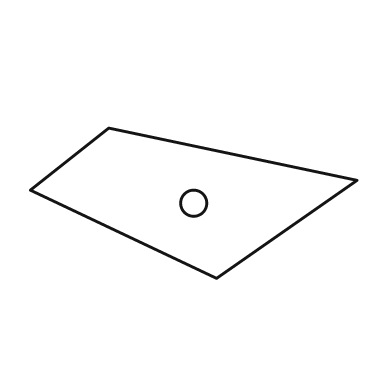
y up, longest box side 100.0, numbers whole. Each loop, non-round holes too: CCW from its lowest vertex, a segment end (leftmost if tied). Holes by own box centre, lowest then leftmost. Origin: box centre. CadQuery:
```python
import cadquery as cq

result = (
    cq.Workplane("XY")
    .moveTo(7.0, -23.0)
    .lineTo(50.0, 7.0)
    .lineTo(-26.0, 23.0)
    .lineTo(-50.0, 4.0)
    .close()
    .moveTo(0.0, 0.0)
    .circle(4.0)
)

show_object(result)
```